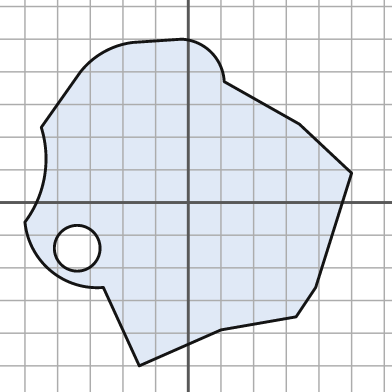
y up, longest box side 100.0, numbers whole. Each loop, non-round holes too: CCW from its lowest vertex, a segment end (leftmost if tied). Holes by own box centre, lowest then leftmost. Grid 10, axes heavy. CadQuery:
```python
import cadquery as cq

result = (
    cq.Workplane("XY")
    .moveTo(-15.0, -50.0)
    .lineTo(10.0, -39.0)
    .lineTo(33.0, -35.0)
    .lineTo(39.0, -26.0)
    .lineTo(50.0, 9.0)
    .lineTo(34.0, 24.0)
    .lineTo(11.0, 37.0)
    .threePointArc((7.0, 46.0), (-2.0, 50.0))
    .lineTo(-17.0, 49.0)
    .threePointArc((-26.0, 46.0), (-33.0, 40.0))
    .lineTo(-45.0, 23.0)
    .threePointArc((-44.0, 8.0), (-50.0, -6.0))
    .threePointArc((-42.0, -21.0), (-26.0, -26.0))
    .close()
    .moveTo(-34.0, -14.0)
    .circle(7.0)
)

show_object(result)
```